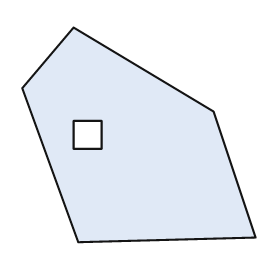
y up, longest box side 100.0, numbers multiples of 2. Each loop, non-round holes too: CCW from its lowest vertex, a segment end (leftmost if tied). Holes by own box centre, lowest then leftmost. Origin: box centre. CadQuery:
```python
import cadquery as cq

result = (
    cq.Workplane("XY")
    .moveTo(-26.0, -46.0)
    .lineTo(50.0, -44.0)
    .lineTo(32.0, 10.0)
    .lineTo(-28.0, 46.0)
    .lineTo(-50.0, 20.0)
    .close()
    .moveTo(-28.0, -6.0)
    .lineTo(-16.0, -6.0)
    .lineTo(-16.0, 6.0)
    .lineTo(-28.0, 6.0)
    .close()
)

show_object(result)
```